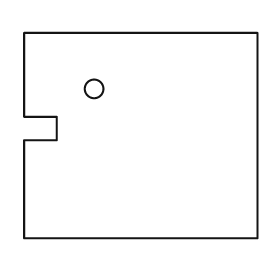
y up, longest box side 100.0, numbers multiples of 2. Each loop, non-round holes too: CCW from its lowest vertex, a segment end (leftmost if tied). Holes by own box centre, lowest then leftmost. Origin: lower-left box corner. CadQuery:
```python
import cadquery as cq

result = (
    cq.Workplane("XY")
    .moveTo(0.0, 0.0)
    .lineTo(100.0, 0.0)
    .lineTo(100.0, 88.0)
    .lineTo(0.0, 88.0)
    .lineTo(0.0, 52.0)
    .lineTo(14.0, 52.0)
    .lineTo(14.0, 42.0)
    .lineTo(0.0, 42.0)
    .close()
    .moveTo(30.0, 64.0)
    .circle(4.0)
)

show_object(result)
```